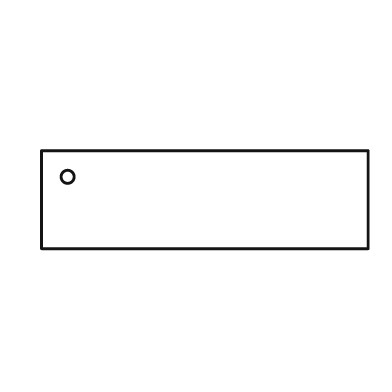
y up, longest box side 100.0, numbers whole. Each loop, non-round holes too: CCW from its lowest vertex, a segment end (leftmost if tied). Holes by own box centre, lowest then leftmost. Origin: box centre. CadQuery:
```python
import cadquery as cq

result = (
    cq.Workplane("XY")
    .moveTo(-50.0, -15.0)
    .lineTo(50.0, -15.0)
    .lineTo(50.0, 15.0)
    .lineTo(-50.0, 15.0)
    .close()
    .moveTo(-42.0, 7.0)
    .circle(2.0)
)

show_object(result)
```